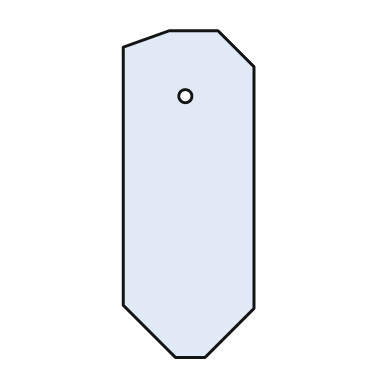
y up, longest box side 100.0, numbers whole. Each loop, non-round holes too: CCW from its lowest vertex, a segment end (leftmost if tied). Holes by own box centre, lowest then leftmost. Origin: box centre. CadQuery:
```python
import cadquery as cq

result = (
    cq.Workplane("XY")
    .moveTo(-4.0, -50.0)
    .lineTo(5.0, -50.0)
    .lineTo(20.0, -35.0)
    .lineTo(20.0, 39.0)
    .lineTo(9.0, 50.0)
    .lineTo(-6.0, 50.0)
    .lineTo(-20.0, 45.0)
    .lineTo(-20.0, -34.0)
    .close()
    .moveTo(-1.0, 30.0)
    .circle(2.0)
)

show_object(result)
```